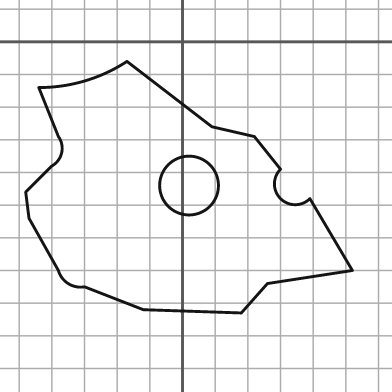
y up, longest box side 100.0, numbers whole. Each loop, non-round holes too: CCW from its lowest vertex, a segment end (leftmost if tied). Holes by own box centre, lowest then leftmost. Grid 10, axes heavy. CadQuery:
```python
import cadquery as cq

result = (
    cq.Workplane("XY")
    .moveTo(18.0, -83.0)
    .lineTo(26.0, -74.0)
    .lineTo(52.0, -70.0)
    .lineTo(39.0, -48.0)
    .threePointArc((30.0, -48.0), (30.0, -39.0))
    .lineTo(22.0, -29.0)
    .lineTo(9.0, -26.0)
    .lineTo(-17.0, -6.0)
    .threePointArc((-30.0, -12.0), (-44.0, -14.0))
    .lineTo(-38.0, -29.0)
    .threePointArc((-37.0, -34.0), (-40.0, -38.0))
    .lineTo(-48.0, -46.0)
    .lineTo(-47.0, -54.0)
    .lineTo(-38.0, -70.0)
    .threePointArc((-35.0, -74.0), (-30.0, -75.0))
    .lineTo(-12.0, -82.0)
    .close()
    .moveTo(2.0, -44.0)
    .circle(9.0)
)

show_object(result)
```